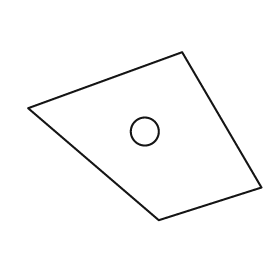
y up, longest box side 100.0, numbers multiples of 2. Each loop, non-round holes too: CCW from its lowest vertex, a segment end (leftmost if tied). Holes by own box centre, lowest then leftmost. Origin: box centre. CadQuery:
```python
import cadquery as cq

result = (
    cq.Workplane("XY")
    .moveTo(6.0, -36.0)
    .lineTo(50.0, -22.0)
    .lineTo(16.0, 36.0)
    .lineTo(-50.0, 12.0)
    .close()
    .moveTo(0.0, 2.0)
    .circle(6.0)
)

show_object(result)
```